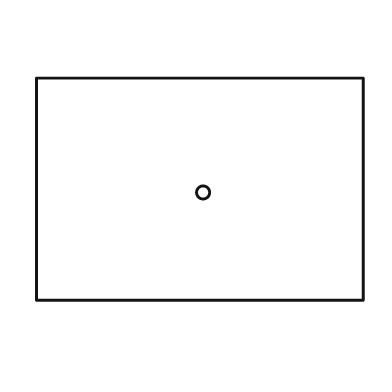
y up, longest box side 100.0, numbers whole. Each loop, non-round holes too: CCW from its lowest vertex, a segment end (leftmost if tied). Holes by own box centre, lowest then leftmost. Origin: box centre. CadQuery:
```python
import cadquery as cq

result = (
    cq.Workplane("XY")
    .moveTo(-50.0, -34.0)
    .lineTo(50.0, -34.0)
    .lineTo(50.0, 34.0)
    .lineTo(-50.0, 34.0)
    .close()
    .moveTo(1.0, -1.0)
    .circle(2.0)
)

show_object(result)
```